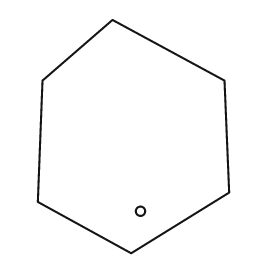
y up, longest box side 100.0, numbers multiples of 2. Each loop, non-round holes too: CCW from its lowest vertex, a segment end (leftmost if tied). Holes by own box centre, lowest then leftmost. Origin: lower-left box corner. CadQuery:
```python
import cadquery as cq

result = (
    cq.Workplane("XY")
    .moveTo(40.0, 0.0)
    .lineTo(82.0, 26.0)
    .lineTo(80.0, 74.0)
    .lineTo(32.0, 100.0)
    .lineTo(2.0, 74.0)
    .lineTo(0.0, 22.0)
    .close()
    .moveTo(44.0, 18.0)
    .circle(2.0)
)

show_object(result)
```